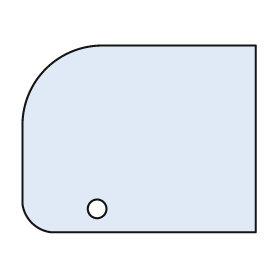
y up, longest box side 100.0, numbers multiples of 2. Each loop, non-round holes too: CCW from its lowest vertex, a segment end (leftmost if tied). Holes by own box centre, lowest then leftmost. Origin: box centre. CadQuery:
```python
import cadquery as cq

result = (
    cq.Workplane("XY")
    .moveTo(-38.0, -40.0)
    .lineTo(50.0, -40.0)
    .lineTo(50.0, 40.0)
    .lineTo(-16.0, 40.0)
    .threePointArc((-40.0, 30.0), (-50.0, 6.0))
    .lineTo(-50.0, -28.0)
    .threePointArc((-46.0, -36.0), (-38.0, -40.0))
    .close()
    .moveTo(-18.0, -30.0)
    .circle(4.0)
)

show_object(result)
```